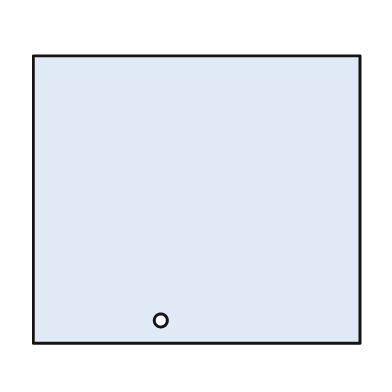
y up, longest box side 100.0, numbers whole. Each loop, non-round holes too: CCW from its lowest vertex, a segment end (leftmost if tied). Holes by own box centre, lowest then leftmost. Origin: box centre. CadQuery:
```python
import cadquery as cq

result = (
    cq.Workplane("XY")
    .moveTo(-50.0, -44.0)
    .lineTo(50.0, -44.0)
    .lineTo(50.0, 44.0)
    .lineTo(-50.0, 44.0)
    .close()
    .moveTo(-11.0, -37.0)
    .circle(2.0)
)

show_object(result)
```